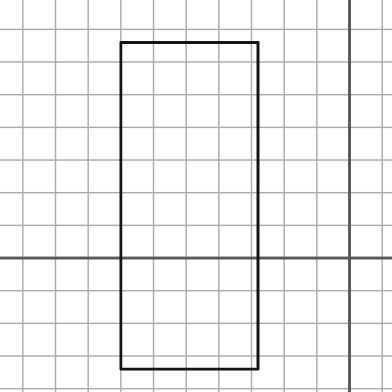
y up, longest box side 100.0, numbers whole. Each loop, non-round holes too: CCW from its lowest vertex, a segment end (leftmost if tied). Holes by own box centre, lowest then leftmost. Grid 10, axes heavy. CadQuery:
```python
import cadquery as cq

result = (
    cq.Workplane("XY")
    .moveTo(-70.0, -34.0)
    .lineTo(-28.0, -34.0)
    .lineTo(-28.0, 66.0)
    .lineTo(-70.0, 66.0)
    .close()
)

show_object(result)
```